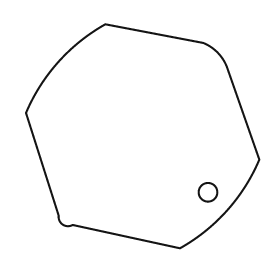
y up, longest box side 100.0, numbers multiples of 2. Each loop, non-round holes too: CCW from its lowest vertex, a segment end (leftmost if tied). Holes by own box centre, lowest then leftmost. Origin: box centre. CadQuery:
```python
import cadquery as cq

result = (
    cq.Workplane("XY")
    .moveTo(16.0, -48.0)
    .threePointArc((36.0, -32.0), (50.0, -10.0))
    .lineTo(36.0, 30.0)
    .threePointArc((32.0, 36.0), (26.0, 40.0))
    .lineTo(-16.0, 48.0)
    .threePointArc((-36.0, 32.0), (-50.0, 10.0))
    .lineTo(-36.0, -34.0)
    .threePointArc((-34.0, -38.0), (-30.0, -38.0))
    .close()
    .moveTo(28.0, -24.0)
    .circle(4.0)
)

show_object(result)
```